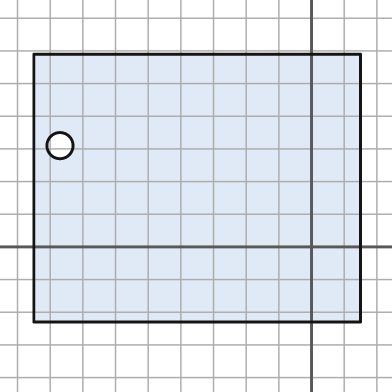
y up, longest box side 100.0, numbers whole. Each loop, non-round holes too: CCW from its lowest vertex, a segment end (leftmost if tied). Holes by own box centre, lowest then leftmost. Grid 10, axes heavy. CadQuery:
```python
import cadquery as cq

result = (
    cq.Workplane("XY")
    .moveTo(-85.0, -23.0)
    .lineTo(15.0, -23.0)
    .lineTo(15.0, 59.0)
    .lineTo(-85.0, 59.0)
    .close()
    .moveTo(-77.0, 31.0)
    .circle(4.0)
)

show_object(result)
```